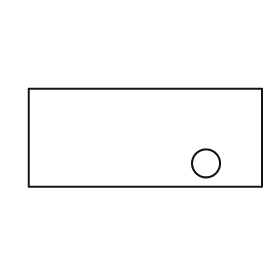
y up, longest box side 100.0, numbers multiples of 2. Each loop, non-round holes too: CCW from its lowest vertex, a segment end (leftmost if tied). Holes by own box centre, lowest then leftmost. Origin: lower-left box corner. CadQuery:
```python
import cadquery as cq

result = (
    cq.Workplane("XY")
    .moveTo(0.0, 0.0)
    .lineTo(100.0, 0.0)
    .lineTo(100.0, 42.0)
    .lineTo(0.0, 42.0)
    .close()
    .moveTo(76.0, 10.0)
    .circle(6.0)
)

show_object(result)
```